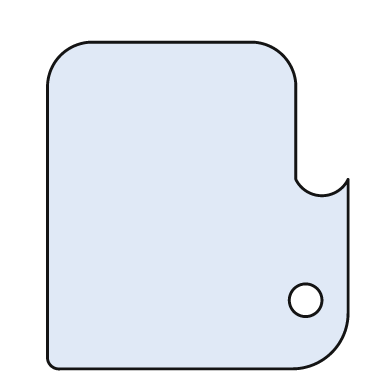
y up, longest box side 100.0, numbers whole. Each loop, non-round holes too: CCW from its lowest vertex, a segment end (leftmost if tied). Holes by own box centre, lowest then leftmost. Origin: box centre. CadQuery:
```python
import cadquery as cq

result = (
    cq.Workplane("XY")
    .moveTo(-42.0, -50.0)
    .lineTo(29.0, -50.0)
    .threePointArc((41.0, -45.0), (46.0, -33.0))
    .lineTo(46.0, 8.0)
    .threePointArc((38.0, 3.0), (30.0, 8.0))
    .lineTo(30.0, 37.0)
    .threePointArc((26.0, 46.0), (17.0, 50.0))
    .lineTo(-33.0, 50.0)
    .threePointArc((-42.0, 46.0), (-46.0, 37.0))
    .lineTo(-46.0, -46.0)
    .threePointArc((-45.0, -49.0), (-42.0, -50.0))
    .close()
    .moveTo(33.0, -29.0)
    .circle(5.0)
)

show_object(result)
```